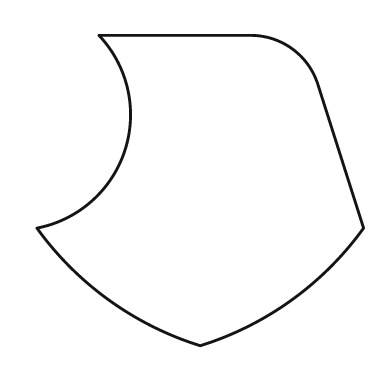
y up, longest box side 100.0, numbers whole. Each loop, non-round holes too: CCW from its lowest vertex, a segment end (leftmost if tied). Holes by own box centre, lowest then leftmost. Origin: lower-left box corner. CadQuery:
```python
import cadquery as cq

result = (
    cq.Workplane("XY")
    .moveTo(50.0, 0.0)
    .threePointArc((78.0, 14.0), (100.0, 36.0))
    .lineTo(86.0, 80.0)
    .threePointArc((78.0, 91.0), (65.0, 95.0))
    .lineTo(19.0, 95.0)
    .threePointArc((27.0, 60.0), (0.0, 36.0))
    .threePointArc((22.0, 14.0), (50.0, 0.0))
    .close()
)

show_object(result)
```